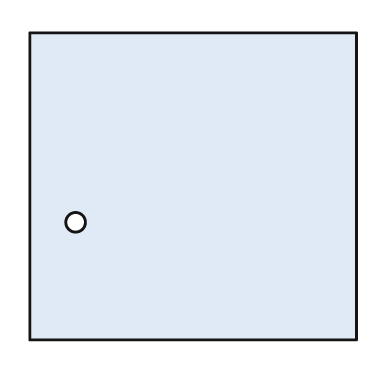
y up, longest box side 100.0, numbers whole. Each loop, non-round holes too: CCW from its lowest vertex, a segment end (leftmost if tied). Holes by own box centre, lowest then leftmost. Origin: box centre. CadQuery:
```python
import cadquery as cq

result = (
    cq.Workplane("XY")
    .moveTo(-50.0, -47.0)
    .lineTo(50.0, -47.0)
    .lineTo(50.0, 47.0)
    .lineTo(-50.0, 47.0)
    .close()
    .moveTo(-36.0, -11.0)
    .circle(3.0)
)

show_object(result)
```